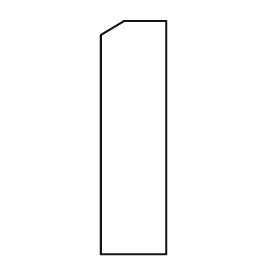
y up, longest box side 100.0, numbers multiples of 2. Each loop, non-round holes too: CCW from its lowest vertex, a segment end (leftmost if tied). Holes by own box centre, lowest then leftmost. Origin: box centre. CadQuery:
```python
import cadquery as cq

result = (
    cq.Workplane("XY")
    .moveTo(-14.0, -50.0)
    .lineTo(14.0, -50.0)
    .lineTo(14.0, 50.0)
    .lineTo(-4.0, 50.0)
    .lineTo(-14.0, 44.0)
    .close()
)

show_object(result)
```